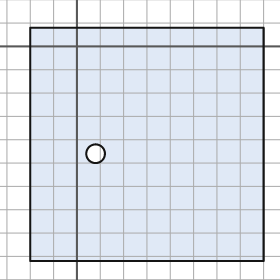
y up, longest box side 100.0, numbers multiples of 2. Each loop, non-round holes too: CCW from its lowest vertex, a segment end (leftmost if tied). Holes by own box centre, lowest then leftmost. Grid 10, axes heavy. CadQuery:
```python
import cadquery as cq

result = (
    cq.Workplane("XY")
    .moveTo(-20.0, -92.0)
    .lineTo(80.0, -92.0)
    .lineTo(80.0, 8.0)
    .lineTo(-20.0, 8.0)
    .close()
    .moveTo(8.0, -46.0)
    .circle(4.0)
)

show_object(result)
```